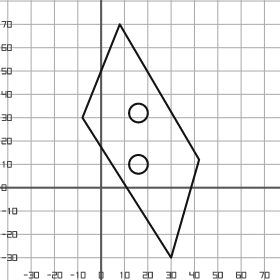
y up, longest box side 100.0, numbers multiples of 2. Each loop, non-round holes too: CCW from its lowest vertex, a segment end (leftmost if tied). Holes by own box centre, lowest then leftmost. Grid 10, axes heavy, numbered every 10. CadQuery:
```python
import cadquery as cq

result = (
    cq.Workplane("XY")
    .moveTo(30.0, -30.0)
    .lineTo(42.0, 12.0)
    .lineTo(8.0, 70.0)
    .lineTo(-8.0, 30.0)
    .close()
    .moveTo(16.0, 10.0)
    .circle(4.0)
    .moveTo(16.0, 32.0)
    .circle(4.0)
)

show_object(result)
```